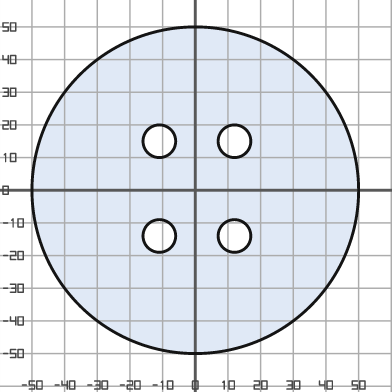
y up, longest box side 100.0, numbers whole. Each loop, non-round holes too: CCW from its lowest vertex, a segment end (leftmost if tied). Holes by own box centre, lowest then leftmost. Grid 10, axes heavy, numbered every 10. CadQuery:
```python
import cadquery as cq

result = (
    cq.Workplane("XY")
    .moveTo(0.0, 0.0)
    .circle(50.0)
    .moveTo(-11.0, -14.0)
    .circle(5.0)
    .moveTo(12.0, -14.0)
    .circle(5.0)
    .moveTo(-11.0, 15.0)
    .circle(5.0)
    .moveTo(12.0, 15.0)
    .circle(5.0)
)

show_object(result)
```